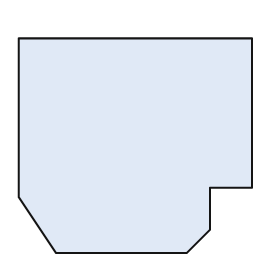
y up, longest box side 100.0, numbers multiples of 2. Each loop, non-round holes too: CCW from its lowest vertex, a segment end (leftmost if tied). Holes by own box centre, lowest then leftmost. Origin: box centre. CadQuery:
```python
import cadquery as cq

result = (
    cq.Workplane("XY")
    .moveTo(-34.0, -46.0)
    .lineTo(22.0, -46.0)
    .lineTo(32.0, -36.0)
    .lineTo(32.0, -18.0)
    .lineTo(50.0, -18.0)
    .lineTo(50.0, 46.0)
    .lineTo(-50.0, 46.0)
    .lineTo(-50.0, -22.0)
    .close()
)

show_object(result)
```